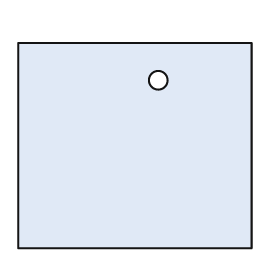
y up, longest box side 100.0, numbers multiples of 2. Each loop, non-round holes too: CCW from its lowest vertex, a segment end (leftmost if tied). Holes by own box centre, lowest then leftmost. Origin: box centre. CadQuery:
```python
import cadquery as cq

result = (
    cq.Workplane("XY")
    .moveTo(-50.0, -44.0)
    .lineTo(50.0, -44.0)
    .lineTo(50.0, 44.0)
    .lineTo(-50.0, 44.0)
    .close()
    .moveTo(10.0, 28.0)
    .circle(4.0)
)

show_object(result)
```